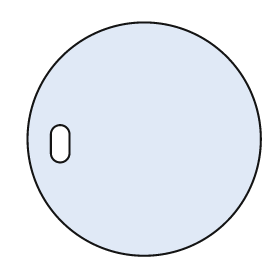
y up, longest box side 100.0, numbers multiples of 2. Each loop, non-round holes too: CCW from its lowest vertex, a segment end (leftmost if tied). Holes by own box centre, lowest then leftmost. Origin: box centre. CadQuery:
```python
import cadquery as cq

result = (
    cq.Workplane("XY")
    .moveTo(0.0, 0.0)
    .circle(50.0)
    .moveTo(-40.0, -6.0)
    .threePointArc((-36.0, -10.0), (-32.0, -6.0))
    .lineTo(-32.0, 2.0)
    .threePointArc((-36.0, 6.0), (-40.0, 2.0))
    .close()
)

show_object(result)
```